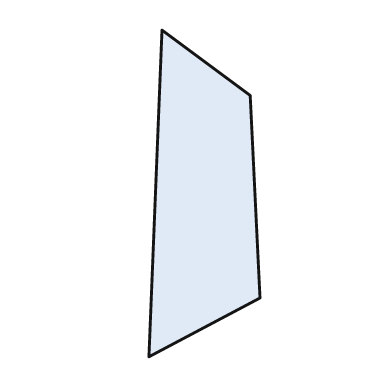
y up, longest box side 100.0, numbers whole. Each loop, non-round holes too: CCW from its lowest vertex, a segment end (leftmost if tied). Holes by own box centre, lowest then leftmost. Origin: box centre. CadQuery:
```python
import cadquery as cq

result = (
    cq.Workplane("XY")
    .moveTo(-17.0, -50.0)
    .lineTo(17.0, -32.0)
    .lineTo(14.0, 30.0)
    .lineTo(-13.0, 50.0)
    .close()
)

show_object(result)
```